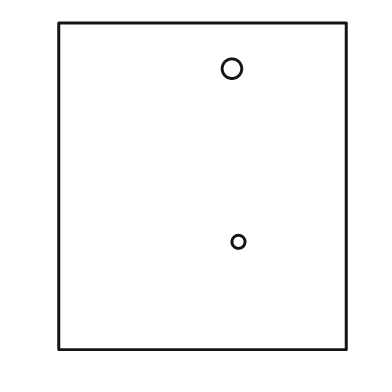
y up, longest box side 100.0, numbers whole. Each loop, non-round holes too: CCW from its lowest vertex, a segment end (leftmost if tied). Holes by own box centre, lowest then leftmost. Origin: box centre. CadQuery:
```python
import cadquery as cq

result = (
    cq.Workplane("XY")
    .moveTo(-44.0, -50.0)
    .lineTo(44.0, -50.0)
    .lineTo(44.0, 50.0)
    .lineTo(-44.0, 50.0)
    .close()
    .moveTo(11.0, -17.0)
    .circle(2.0)
    .moveTo(9.0, 36.0)
    .circle(3.0)
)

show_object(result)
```